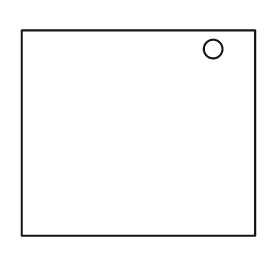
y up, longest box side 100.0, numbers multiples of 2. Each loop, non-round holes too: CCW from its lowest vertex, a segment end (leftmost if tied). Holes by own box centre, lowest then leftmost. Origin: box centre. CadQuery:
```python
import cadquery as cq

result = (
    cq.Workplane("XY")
    .moveTo(-50.0, -44.0)
    .lineTo(50.0, -44.0)
    .lineTo(50.0, 44.0)
    .lineTo(-50.0, 44.0)
    .close()
    .moveTo(32.0, 36.0)
    .circle(4.0)
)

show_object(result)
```